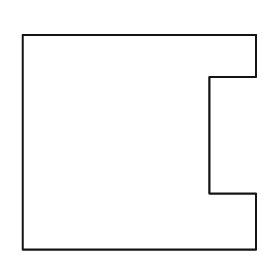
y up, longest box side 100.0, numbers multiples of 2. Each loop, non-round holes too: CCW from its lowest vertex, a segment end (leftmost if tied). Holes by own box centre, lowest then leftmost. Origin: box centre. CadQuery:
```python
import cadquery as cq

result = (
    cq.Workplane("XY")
    .moveTo(-50.0, -46.0)
    .lineTo(50.0, -46.0)
    .lineTo(50.0, -22.0)
    .lineTo(30.0, -22.0)
    .lineTo(30.0, 28.0)
    .lineTo(50.0, 28.0)
    .lineTo(50.0, 46.0)
    .lineTo(-50.0, 46.0)
    .close()
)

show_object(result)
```